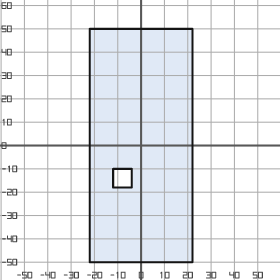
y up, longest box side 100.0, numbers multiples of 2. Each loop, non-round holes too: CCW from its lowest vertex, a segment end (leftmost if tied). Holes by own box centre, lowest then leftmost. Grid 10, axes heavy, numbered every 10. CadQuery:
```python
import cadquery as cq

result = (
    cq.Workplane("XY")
    .moveTo(-22.0, -50.0)
    .lineTo(22.0, -50.0)
    .lineTo(22.0, 50.0)
    .lineTo(-22.0, 50.0)
    .close()
    .moveTo(-12.0, -18.0)
    .lineTo(-4.0, -18.0)
    .lineTo(-4.0, -10.0)
    .lineTo(-12.0, -10.0)
    .close()
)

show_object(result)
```